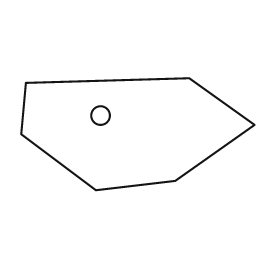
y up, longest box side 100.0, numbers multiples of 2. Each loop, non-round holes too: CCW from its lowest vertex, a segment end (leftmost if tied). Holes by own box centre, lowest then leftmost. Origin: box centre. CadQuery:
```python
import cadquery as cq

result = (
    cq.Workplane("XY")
    .moveTo(-18.0, -24.0)
    .lineTo(16.0, -20.0)
    .lineTo(50.0, 4.0)
    .lineTo(22.0, 24.0)
    .lineTo(-48.0, 22.0)
    .lineTo(-50.0, 0.0)
    .close()
    .moveTo(-16.0, 8.0)
    .circle(4.0)
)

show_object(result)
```